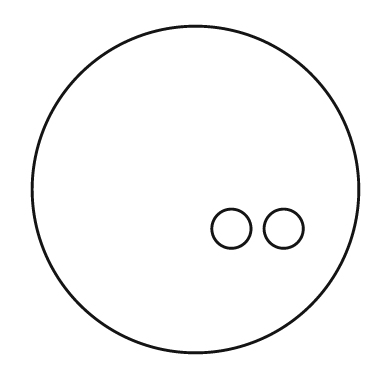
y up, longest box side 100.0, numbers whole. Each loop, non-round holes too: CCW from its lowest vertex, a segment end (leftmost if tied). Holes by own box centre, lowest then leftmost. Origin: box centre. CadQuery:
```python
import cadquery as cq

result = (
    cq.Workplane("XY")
    .moveTo(0.0, 0.0)
    .circle(50.0)
    .moveTo(11.0, -12.0)
    .circle(6.0)
    .moveTo(27.0, -12.0)
    .circle(6.0)
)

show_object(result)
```